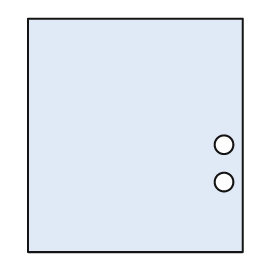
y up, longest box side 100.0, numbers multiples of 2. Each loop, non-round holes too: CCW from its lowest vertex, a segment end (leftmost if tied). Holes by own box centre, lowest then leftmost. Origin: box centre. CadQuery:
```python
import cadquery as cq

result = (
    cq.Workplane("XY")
    .moveTo(-46.0, -50.0)
    .lineTo(46.0, -50.0)
    .lineTo(46.0, 50.0)
    .lineTo(-46.0, 50.0)
    .close()
    .moveTo(38.0, -20.0)
    .circle(4.0)
    .moveTo(38.0, -4.0)
    .circle(4.0)
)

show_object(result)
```